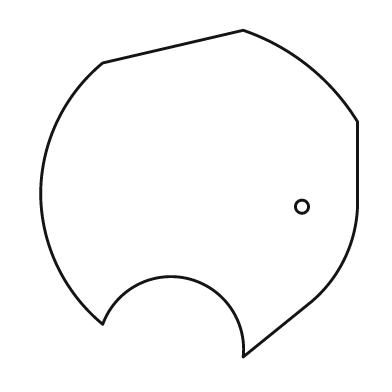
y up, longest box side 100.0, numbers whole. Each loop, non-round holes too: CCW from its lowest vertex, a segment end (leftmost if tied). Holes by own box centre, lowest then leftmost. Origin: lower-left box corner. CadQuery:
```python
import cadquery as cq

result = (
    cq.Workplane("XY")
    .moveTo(62.0, 0.0)
    .lineTo(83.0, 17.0)
    .threePointArc((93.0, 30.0), (97.0, 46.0))
    .lineTo(97.0, 72.0)
    .threePointArc((82.0, 89.0), (62.0, 100.0))
    .lineTo(19.0, 90.0)
    .threePointArc((5.0, 72.0), (0.0, 50.0))
    .threePointArc((5.0, 28.0), (19.0, 10.0))
    .threePointArc((45.0, 24.0), (62.0, 0.0))
    .close()
    .moveTo(80.0, 46.0)
    .circle(2.0)
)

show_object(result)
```